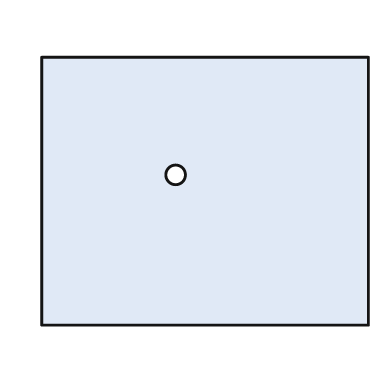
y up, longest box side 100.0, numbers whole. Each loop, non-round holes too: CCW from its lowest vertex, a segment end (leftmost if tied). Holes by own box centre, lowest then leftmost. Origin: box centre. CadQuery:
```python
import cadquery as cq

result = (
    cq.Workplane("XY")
    .moveTo(-50.0, -41.0)
    .lineTo(50.0, -41.0)
    .lineTo(50.0, 41.0)
    .lineTo(-50.0, 41.0)
    .close()
    .moveTo(-9.0, 5.0)
    .circle(3.0)
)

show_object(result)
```